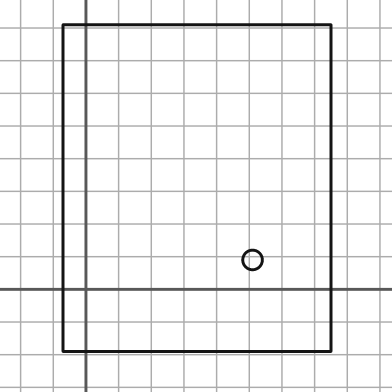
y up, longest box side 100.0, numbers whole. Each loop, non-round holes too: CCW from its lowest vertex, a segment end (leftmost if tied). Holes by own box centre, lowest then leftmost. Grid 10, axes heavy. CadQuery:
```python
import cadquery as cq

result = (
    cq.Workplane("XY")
    .moveTo(-7.0, -19.0)
    .lineTo(75.0, -19.0)
    .lineTo(75.0, 81.0)
    .lineTo(-7.0, 81.0)
    .close()
    .moveTo(51.0, 9.0)
    .circle(3.0)
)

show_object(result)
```